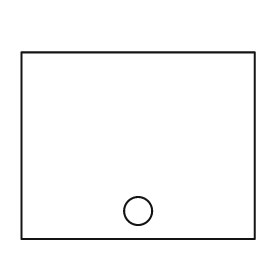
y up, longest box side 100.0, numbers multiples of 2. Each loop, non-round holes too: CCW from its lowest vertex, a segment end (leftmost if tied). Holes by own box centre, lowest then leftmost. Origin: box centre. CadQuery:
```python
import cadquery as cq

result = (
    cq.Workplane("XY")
    .moveTo(-50.0, -40.0)
    .lineTo(50.0, -40.0)
    .lineTo(50.0, 40.0)
    .lineTo(-50.0, 40.0)
    .close()
    .moveTo(0.0, -28.0)
    .circle(6.0)
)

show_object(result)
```